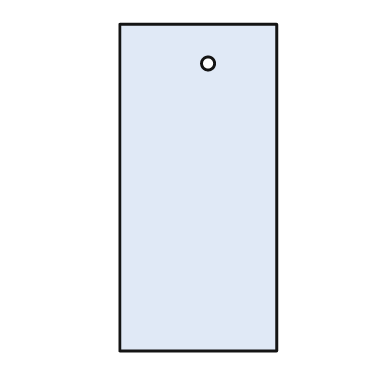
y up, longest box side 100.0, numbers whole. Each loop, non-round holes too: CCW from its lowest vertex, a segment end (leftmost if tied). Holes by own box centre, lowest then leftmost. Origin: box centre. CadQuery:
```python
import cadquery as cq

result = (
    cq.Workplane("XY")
    .moveTo(-24.0, -50.0)
    .lineTo(24.0, -50.0)
    .lineTo(24.0, 50.0)
    .lineTo(-24.0, 50.0)
    .close()
    .moveTo(3.0, 38.0)
    .circle(2.0)
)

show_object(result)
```